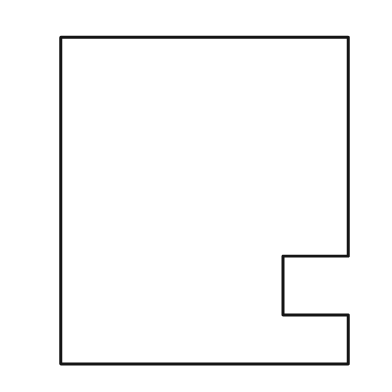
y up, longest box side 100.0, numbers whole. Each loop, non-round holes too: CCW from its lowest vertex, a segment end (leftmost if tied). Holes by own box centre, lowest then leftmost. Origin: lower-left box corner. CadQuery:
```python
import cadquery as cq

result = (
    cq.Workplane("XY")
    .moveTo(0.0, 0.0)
    .lineTo(88.0, 0.0)
    .lineTo(88.0, 15.0)
    .lineTo(68.0, 15.0)
    .lineTo(68.0, 33.0)
    .lineTo(88.0, 33.0)
    .lineTo(88.0, 100.0)
    .lineTo(0.0, 100.0)
    .close()
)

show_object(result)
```